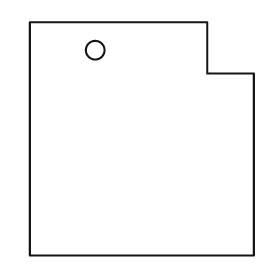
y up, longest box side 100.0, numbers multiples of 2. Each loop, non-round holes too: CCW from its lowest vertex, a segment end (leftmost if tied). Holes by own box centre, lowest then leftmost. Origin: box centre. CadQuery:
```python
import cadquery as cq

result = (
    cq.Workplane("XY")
    .moveTo(-48.0, -50.0)
    .lineTo(48.0, -50.0)
    .lineTo(48.0, 28.0)
    .lineTo(28.0, 28.0)
    .lineTo(28.0, 50.0)
    .lineTo(-48.0, 50.0)
    .close()
    .moveTo(-20.0, 38.0)
    .circle(4.0)
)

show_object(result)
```